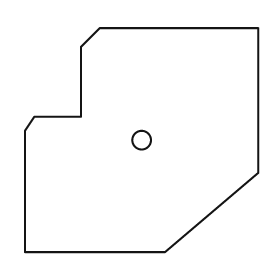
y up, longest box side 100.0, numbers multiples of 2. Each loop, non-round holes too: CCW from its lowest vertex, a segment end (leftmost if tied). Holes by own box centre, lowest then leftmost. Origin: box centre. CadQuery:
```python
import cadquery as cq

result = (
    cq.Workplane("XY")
    .moveTo(-50.0, -48.0)
    .lineTo(10.0, -48.0)
    .lineTo(50.0, -14.0)
    .lineTo(50.0, 48.0)
    .lineTo(-18.0, 48.0)
    .lineTo(-26.0, 40.0)
    .lineTo(-26.0, 10.0)
    .lineTo(-46.0, 10.0)
    .lineTo(-50.0, 4.0)
    .close()
    .moveTo(0.0, 0.0)
    .circle(4.0)
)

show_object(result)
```